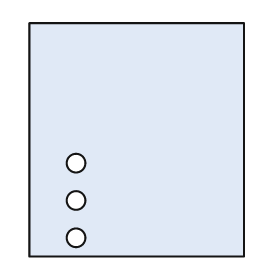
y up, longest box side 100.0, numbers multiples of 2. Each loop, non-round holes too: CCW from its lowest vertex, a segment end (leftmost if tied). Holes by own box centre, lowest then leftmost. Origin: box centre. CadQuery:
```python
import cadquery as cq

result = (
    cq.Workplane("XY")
    .moveTo(-46.0, -50.0)
    .lineTo(46.0, -50.0)
    .lineTo(46.0, 50.0)
    .lineTo(-46.0, 50.0)
    .close()
    .moveTo(-26.0, -42.0)
    .circle(4.0)
    .moveTo(-26.0, -26.0)
    .circle(4.0)
    .moveTo(-26.0, -10.0)
    .circle(4.0)
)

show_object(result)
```